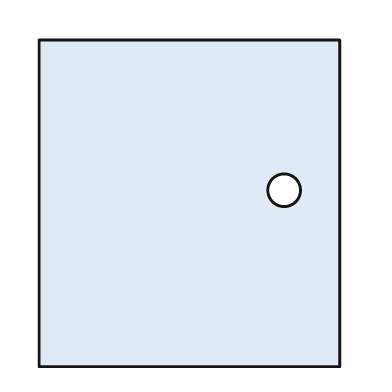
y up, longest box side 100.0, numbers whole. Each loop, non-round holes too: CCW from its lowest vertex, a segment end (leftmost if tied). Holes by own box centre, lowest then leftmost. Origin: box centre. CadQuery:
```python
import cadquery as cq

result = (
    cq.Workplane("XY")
    .moveTo(-46.0, -50.0)
    .lineTo(46.0, -50.0)
    .lineTo(46.0, 50.0)
    .lineTo(-46.0, 50.0)
    .close()
    .moveTo(29.0, 4.0)
    .circle(5.0)
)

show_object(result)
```